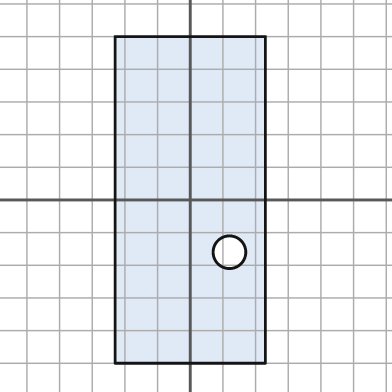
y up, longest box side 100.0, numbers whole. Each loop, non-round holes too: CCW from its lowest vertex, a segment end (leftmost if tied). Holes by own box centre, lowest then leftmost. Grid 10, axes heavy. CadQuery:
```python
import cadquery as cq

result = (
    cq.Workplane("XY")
    .moveTo(-23.0, -50.0)
    .lineTo(23.0, -50.0)
    .lineTo(23.0, 50.0)
    .lineTo(-23.0, 50.0)
    .close()
    .moveTo(12.0, -16.0)
    .circle(5.0)
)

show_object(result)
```